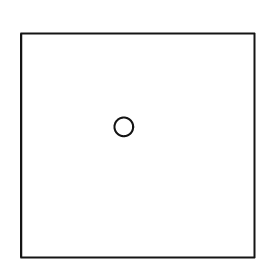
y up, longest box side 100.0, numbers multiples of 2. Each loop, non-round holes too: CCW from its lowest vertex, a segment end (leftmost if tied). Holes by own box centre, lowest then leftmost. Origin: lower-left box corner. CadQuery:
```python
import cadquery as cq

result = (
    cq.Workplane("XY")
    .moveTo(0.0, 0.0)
    .lineTo(100.0, 0.0)
    .lineTo(100.0, 96.0)
    .lineTo(0.0, 96.0)
    .close()
    .moveTo(44.0, 56.0)
    .circle(4.0)
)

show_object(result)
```